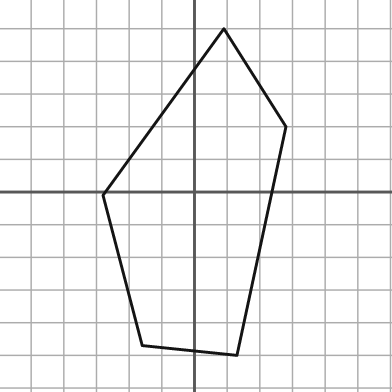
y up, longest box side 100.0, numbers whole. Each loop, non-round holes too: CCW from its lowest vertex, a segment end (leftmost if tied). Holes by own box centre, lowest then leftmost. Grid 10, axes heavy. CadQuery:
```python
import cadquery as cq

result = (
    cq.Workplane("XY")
    .moveTo(13.0, -50.0)
    .lineTo(28.0, 20.0)
    .lineTo(9.0, 50.0)
    .lineTo(-28.0, -1.0)
    .lineTo(-16.0, -47.0)
    .close()
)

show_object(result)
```